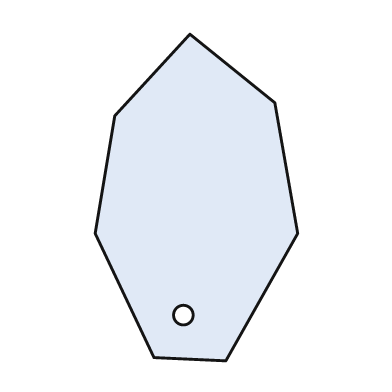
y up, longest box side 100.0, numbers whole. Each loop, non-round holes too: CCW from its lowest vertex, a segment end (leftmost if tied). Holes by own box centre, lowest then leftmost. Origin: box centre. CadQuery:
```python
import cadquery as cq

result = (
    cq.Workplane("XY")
    .moveTo(9.0, -50.0)
    .lineTo(31.0, -11.0)
    .lineTo(24.0, 29.0)
    .lineTo(-2.0, 50.0)
    .lineTo(-25.0, 25.0)
    .lineTo(-31.0, -11.0)
    .lineTo(-13.0, -49.0)
    .close()
    .moveTo(-4.0, -36.0)
    .circle(3.0)
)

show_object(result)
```